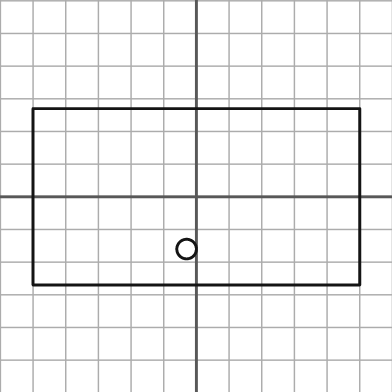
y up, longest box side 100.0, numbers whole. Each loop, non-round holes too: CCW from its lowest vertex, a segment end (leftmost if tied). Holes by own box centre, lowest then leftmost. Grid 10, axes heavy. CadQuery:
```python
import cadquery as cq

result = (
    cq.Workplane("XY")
    .moveTo(-50.0, -27.0)
    .lineTo(50.0, -27.0)
    .lineTo(50.0, 27.0)
    .lineTo(-50.0, 27.0)
    .close()
    .moveTo(-3.0, -16.0)
    .circle(3.0)
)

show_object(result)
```